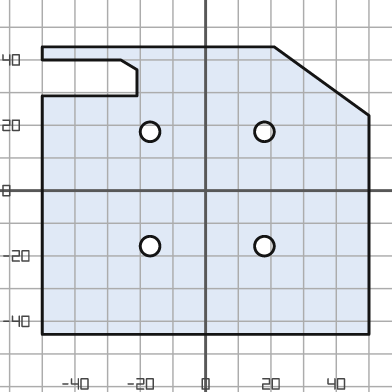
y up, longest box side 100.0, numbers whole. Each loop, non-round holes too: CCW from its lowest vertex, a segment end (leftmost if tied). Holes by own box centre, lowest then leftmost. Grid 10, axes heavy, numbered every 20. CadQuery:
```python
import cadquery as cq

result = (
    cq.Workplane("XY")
    .moveTo(-50.0, -44.0)
    .lineTo(50.0, -44.0)
    .lineTo(50.0, 23.0)
    .lineTo(21.0, 44.0)
    .lineTo(-50.0, 44.0)
    .lineTo(-50.0, 40.0)
    .lineTo(-26.0, 40.0)
    .lineTo(-21.0, 37.0)
    .lineTo(-21.0, 29.0)
    .lineTo(-50.0, 29.0)
    .close()
    .moveTo(-17.0, -17.0)
    .circle(3.0)
    .moveTo(18.0, -17.0)
    .circle(3.0)
    .moveTo(-17.0, 18.0)
    .circle(3.0)
    .moveTo(18.0, 18.0)
    .circle(3.0)
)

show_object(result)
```